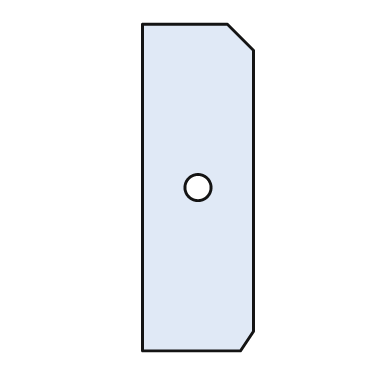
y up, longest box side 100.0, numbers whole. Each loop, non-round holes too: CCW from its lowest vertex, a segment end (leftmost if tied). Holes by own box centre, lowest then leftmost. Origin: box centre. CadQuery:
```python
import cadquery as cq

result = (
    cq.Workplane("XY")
    .moveTo(-17.0, -50.0)
    .lineTo(13.0, -50.0)
    .lineTo(17.0, -44.0)
    .lineTo(17.0, 42.0)
    .lineTo(9.0, 50.0)
    .lineTo(-17.0, 50.0)
    .close()
    .moveTo(0.0, 0.0)
    .circle(4.0)
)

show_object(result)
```